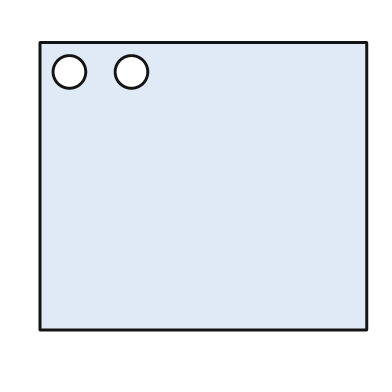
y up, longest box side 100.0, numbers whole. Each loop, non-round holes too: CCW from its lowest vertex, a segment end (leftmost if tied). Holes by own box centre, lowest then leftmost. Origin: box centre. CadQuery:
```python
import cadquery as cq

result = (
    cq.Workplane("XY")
    .moveTo(-50.0, -44.0)
    .lineTo(50.0, -44.0)
    .lineTo(50.0, 44.0)
    .lineTo(-50.0, 44.0)
    .close()
    .moveTo(-41.0, 35.0)
    .circle(5.0)
    .moveTo(-22.0, 35.0)
    .circle(5.0)
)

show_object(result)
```